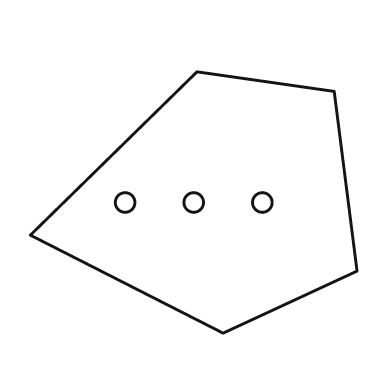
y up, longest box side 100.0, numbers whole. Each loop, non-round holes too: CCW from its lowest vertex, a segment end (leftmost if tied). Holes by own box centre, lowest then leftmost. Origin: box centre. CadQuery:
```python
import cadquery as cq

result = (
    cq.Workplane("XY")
    .moveTo(9.0, -40.0)
    .lineTo(50.0, -21.0)
    .lineTo(43.0, 34.0)
    .lineTo(1.0, 40.0)
    .lineTo(-50.0, -10.0)
    .close()
    .moveTo(-21.0, 0.0)
    .circle(3.0)
    .moveTo(0.0, 0.0)
    .circle(3.0)
    .moveTo(21.0, 0.0)
    .circle(3.0)
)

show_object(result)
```